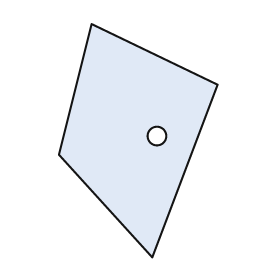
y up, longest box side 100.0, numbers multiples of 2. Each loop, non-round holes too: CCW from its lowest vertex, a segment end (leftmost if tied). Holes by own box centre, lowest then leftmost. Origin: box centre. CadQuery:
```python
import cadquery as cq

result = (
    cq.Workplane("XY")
    .moveTo(6.0, -50.0)
    .lineTo(34.0, 24.0)
    .lineTo(-20.0, 50.0)
    .lineTo(-34.0, -6.0)
    .close()
    .moveTo(8.0, 2.0)
    .circle(4.0)
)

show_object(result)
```